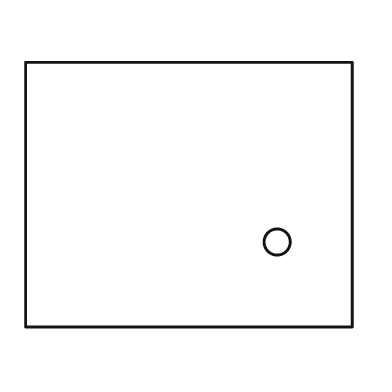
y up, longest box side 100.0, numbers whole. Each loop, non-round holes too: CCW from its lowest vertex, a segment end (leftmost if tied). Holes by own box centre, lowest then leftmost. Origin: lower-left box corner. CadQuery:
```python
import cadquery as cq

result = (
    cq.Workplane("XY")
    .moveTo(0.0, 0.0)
    .lineTo(100.0, 0.0)
    .lineTo(100.0, 81.0)
    .lineTo(0.0, 81.0)
    .close()
    .moveTo(77.0, 26.0)
    .circle(4.0)
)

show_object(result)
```